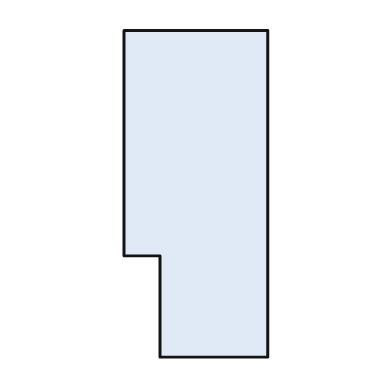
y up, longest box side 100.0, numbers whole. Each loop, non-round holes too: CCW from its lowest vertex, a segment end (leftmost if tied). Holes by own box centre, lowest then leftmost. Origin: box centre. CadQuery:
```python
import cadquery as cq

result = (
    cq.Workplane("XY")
    .moveTo(-11.0, -50.0)
    .lineTo(22.0, -50.0)
    .lineTo(22.0, 50.0)
    .lineTo(-22.0, 50.0)
    .lineTo(-22.0, -19.0)
    .lineTo(-11.0, -19.0)
    .close()
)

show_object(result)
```